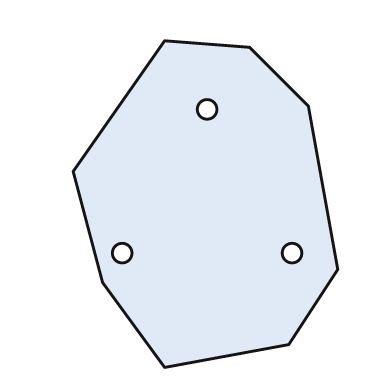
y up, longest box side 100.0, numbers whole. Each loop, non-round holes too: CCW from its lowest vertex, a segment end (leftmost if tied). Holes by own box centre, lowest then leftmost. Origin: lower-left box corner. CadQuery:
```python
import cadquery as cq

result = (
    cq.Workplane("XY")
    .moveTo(28.0, 0.0)
    .lineTo(66.0, 7.0)
    .lineTo(81.0, 30.0)
    .lineTo(72.0, 80.0)
    .lineTo(54.0, 98.0)
    .lineTo(28.0, 100.0)
    .lineTo(0.0, 60.0)
    .lineTo(9.0, 26.0)
    .close()
    .moveTo(15.0, 35.0)
    .circle(3.0)
    .moveTo(67.0, 35.0)
    .circle(3.0)
    .moveTo(41.0, 79.0)
    .circle(3.0)
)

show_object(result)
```